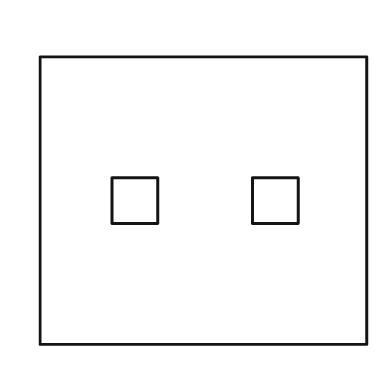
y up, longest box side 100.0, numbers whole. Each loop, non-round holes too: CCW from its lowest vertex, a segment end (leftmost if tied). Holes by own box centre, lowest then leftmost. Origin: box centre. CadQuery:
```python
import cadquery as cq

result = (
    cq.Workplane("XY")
    .moveTo(-50.0, -44.0)
    .lineTo(50.0, -44.0)
    .lineTo(50.0, 44.0)
    .lineTo(-50.0, 44.0)
    .close()
    .moveTo(-28.0, -7.0)
    .lineTo(-14.0, -7.0)
    .lineTo(-14.0, 7.0)
    .lineTo(-28.0, 7.0)
    .close()
    .moveTo(15.0, -7.0)
    .lineTo(29.0, -7.0)
    .lineTo(29.0, 7.0)
    .lineTo(15.0, 7.0)
    .close()
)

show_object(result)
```